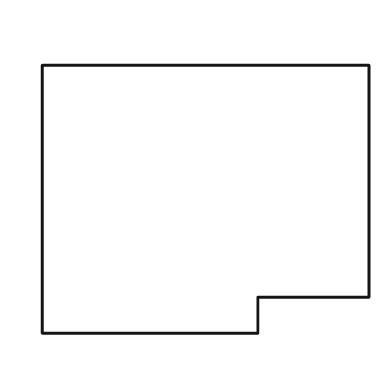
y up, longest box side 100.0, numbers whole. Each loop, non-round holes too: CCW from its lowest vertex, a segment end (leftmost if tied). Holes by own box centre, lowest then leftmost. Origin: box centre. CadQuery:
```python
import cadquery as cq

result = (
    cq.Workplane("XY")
    .moveTo(-50.0, -41.0)
    .lineTo(16.0, -41.0)
    .lineTo(16.0, -30.0)
    .lineTo(50.0, -30.0)
    .lineTo(50.0, 41.0)
    .lineTo(-50.0, 41.0)
    .close()
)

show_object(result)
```